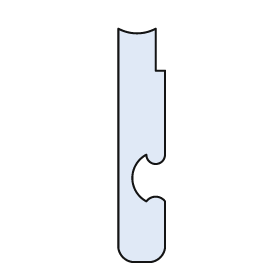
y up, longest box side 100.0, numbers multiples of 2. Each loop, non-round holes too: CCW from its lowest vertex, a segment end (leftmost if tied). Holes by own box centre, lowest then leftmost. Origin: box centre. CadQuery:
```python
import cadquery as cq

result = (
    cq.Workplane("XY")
    .moveTo(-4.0, -50.0)
    .lineTo(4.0, -50.0)
    .threePointArc((8.0, -48.0), (10.0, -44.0))
    .lineTo(10.0, -24.0)
    .threePointArc((6.0, -22.0), (2.0, -24.0))
    .threePointArc((-4.0, -14.0), (2.0, -4.0))
    .threePointArc((6.0, -8.0), (10.0, -4.0))
    .lineTo(10.0, 32.0)
    .lineTo(6.0, 32.0)
    .lineTo(6.0, 50.0)
    .threePointArc((-2.0, 48.0), (-10.0, 50.0))
    .lineTo(-10.0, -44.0)
    .threePointArc((-8.0, -48.0), (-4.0, -50.0))
    .close()
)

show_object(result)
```